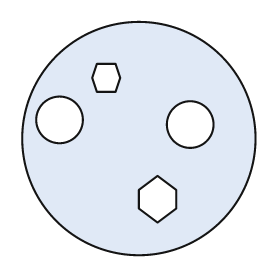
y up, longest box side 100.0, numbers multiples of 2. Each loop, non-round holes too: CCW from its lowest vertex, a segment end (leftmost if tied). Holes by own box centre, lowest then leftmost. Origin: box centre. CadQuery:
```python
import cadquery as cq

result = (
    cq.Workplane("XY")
    .moveTo(0.0, 0.0)
    .circle(50.0)
    .moveTo(8.0, -36.0)
    .lineTo(16.0, -30.0)
    .lineTo(16.0, -22.0)
    .lineTo(8.0, -16.0)
    .lineTo(0.0, -22.0)
    .lineTo(0.0, -30.0)
    .close()
    .moveTo(22.0, 6.0)
    .circle(10.0)
    .moveTo(-34.0, 8.0)
    .circle(10.0)
    .moveTo(-18.0, 20.0)
    .lineTo(-10.0, 20.0)
    .lineTo(-8.0, 26.0)
    .lineTo(-10.0, 32.0)
    .lineTo(-18.0, 32.0)
    .lineTo(-20.0, 26.0)
    .close()
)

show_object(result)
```